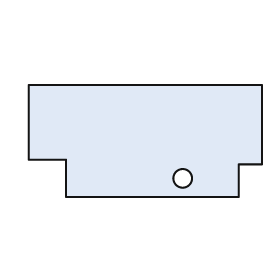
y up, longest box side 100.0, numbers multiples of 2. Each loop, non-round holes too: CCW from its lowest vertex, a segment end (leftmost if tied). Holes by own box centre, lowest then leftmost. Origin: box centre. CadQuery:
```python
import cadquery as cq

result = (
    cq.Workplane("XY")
    .moveTo(-34.0, -24.0)
    .lineTo(40.0, -24.0)
    .lineTo(40.0, -10.0)
    .lineTo(50.0, -10.0)
    .lineTo(50.0, 24.0)
    .lineTo(-50.0, 24.0)
    .lineTo(-50.0, -8.0)
    .lineTo(-34.0, -8.0)
    .close()
    .moveTo(16.0, -16.0)
    .circle(4.0)
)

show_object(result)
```